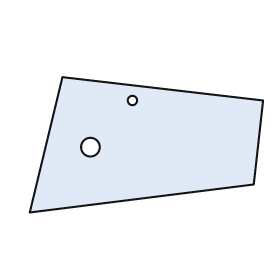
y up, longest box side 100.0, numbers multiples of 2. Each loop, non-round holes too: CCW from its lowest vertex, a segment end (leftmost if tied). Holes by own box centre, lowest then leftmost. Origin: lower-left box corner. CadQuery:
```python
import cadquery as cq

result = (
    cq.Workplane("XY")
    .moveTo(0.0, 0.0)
    .lineTo(96.0, 12.0)
    .lineTo(100.0, 48.0)
    .lineTo(14.0, 58.0)
    .close()
    .moveTo(26.0, 28.0)
    .circle(4.0)
    .moveTo(44.0, 48.0)
    .circle(2.0)
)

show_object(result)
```